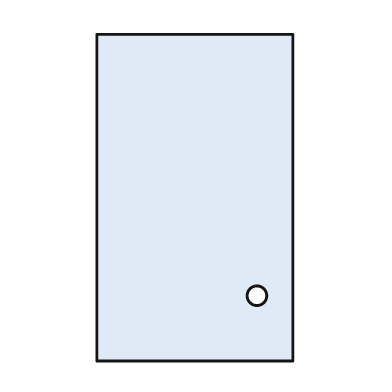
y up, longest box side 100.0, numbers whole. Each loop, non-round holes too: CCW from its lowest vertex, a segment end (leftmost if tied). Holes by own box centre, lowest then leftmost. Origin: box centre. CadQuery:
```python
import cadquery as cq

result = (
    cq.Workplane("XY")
    .moveTo(-30.0, -50.0)
    .lineTo(30.0, -50.0)
    .lineTo(30.0, 50.0)
    .lineTo(-30.0, 50.0)
    .close()
    .moveTo(19.0, -30.0)
    .circle(3.0)
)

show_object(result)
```